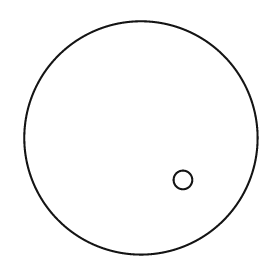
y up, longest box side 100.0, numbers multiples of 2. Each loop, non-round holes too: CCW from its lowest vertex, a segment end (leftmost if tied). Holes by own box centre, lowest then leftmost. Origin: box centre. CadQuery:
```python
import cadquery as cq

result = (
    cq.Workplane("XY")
    .moveTo(0.0, 0.0)
    .circle(50.0)
    .moveTo(18.0, -18.0)
    .circle(4.0)
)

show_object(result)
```